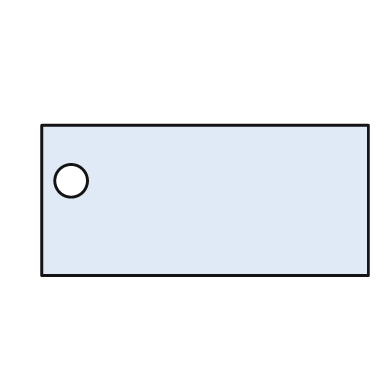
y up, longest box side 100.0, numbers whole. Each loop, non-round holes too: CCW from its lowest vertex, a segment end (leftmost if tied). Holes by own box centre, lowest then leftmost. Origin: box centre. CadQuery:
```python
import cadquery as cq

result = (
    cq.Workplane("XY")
    .moveTo(-50.0, -23.0)
    .lineTo(50.0, -23.0)
    .lineTo(50.0, 23.0)
    .lineTo(-50.0, 23.0)
    .close()
    .moveTo(-41.0, 6.0)
    .circle(5.0)
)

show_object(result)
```